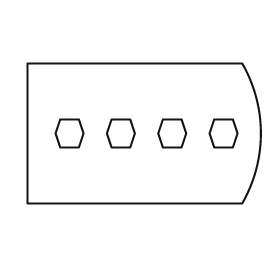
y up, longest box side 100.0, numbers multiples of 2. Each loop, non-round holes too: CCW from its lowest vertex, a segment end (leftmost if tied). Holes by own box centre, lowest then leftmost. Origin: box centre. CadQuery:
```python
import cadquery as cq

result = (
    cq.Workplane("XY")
    .moveTo(-50.0, -30.0)
    .lineTo(42.0, -30.0)
    .threePointArc((50.0, 0.0), (42.0, 30.0))
    .lineTo(-50.0, 30.0)
    .close()
    .moveTo(-36.0, -6.0)
    .lineTo(-28.0, -6.0)
    .lineTo(-26.0, 0.0)
    .lineTo(-28.0, 6.0)
    .lineTo(-36.0, 6.0)
    .lineTo(-38.0, 0.0)
    .close()
    .moveTo(-14.0, -6.0)
    .lineTo(-6.0, -6.0)
    .lineTo(-4.0, 0.0)
    .lineTo(-6.0, 6.0)
    .lineTo(-14.0, 6.0)
    .lineTo(-16.0, 0.0)
    .close()
    .moveTo(8.0, -6.0)
    .lineTo(16.0, -6.0)
    .lineTo(18.0, 0.0)
    .lineTo(16.0, 6.0)
    .lineTo(8.0, 6.0)
    .lineTo(6.0, 0.0)
    .close()
    .moveTo(30.0, -6.0)
    .lineTo(38.0, -6.0)
    .lineTo(40.0, 0.0)
    .lineTo(38.0, 6.0)
    .lineTo(30.0, 6.0)
    .lineTo(28.0, 0.0)
    .close()
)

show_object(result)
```